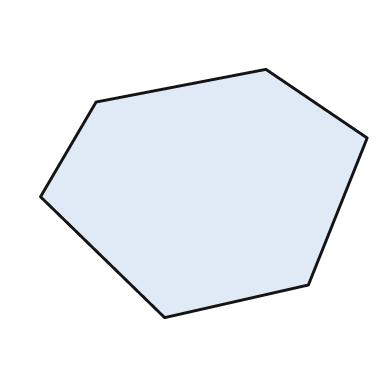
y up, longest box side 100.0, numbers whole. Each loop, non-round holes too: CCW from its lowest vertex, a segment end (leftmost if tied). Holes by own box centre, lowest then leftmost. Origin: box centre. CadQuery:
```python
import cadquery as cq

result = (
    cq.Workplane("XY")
    .moveTo(-12.0, -38.0)
    .lineTo(32.0, -28.0)
    .lineTo(50.0, 17.0)
    .lineTo(19.0, 38.0)
    .lineTo(-33.0, 28.0)
    .lineTo(-50.0, -1.0)
    .close()
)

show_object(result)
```